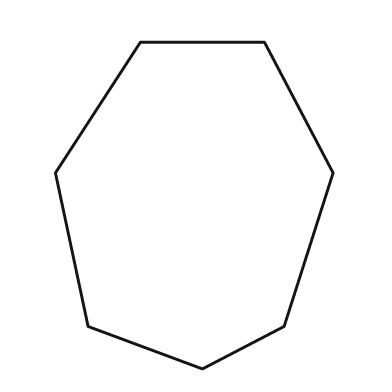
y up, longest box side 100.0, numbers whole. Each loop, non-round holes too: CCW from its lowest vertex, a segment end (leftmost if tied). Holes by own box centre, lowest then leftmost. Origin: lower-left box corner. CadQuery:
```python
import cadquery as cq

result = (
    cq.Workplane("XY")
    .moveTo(45.0, 0.0)
    .lineTo(70.0, 13.0)
    .lineTo(85.0, 60.0)
    .lineTo(64.0, 100.0)
    .lineTo(26.0, 100.0)
    .lineTo(0.0, 60.0)
    .lineTo(10.0, 13.0)
    .close()
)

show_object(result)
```